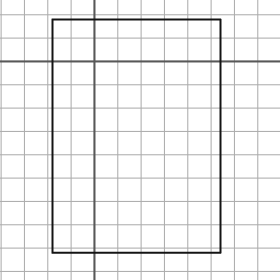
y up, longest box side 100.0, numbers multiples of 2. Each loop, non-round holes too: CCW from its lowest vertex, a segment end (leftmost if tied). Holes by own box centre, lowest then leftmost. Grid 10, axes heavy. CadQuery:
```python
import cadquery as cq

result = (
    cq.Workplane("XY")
    .moveTo(-18.0, -82.0)
    .lineTo(54.0, -82.0)
    .lineTo(54.0, 18.0)
    .lineTo(-18.0, 18.0)
    .close()
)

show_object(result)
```